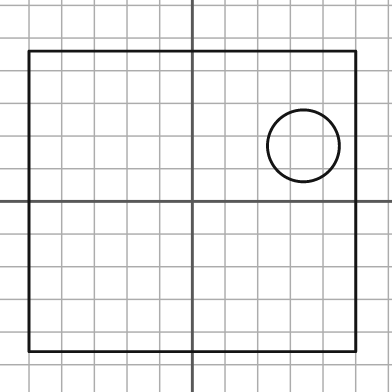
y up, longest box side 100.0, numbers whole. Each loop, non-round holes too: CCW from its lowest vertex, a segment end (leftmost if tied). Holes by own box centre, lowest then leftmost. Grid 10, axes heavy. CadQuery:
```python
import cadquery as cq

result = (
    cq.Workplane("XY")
    .moveTo(-50.0, -46.0)
    .lineTo(50.0, -46.0)
    .lineTo(50.0, 46.0)
    .lineTo(-50.0, 46.0)
    .close()
    .moveTo(34.0, 17.0)
    .circle(11.0)
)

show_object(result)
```